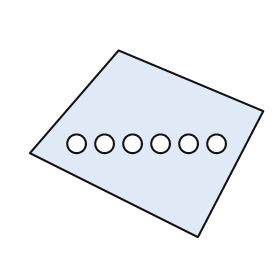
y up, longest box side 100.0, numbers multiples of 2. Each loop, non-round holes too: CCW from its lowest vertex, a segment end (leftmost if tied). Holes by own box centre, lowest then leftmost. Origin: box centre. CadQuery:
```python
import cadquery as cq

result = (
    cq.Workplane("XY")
    .moveTo(22.0, -40.0)
    .lineTo(50.0, 14.0)
    .lineTo(-12.0, 40.0)
    .lineTo(-50.0, -4.0)
    .close()
    .moveTo(-30.0, 0.0)
    .circle(4.0)
    .moveTo(-18.0, 0.0)
    .circle(4.0)
    .moveTo(-6.0, 0.0)
    .circle(4.0)
    .moveTo(6.0, 0.0)
    .circle(4.0)
    .moveTo(18.0, 0.0)
    .circle(4.0)
    .moveTo(30.0, 0.0)
    .circle(4.0)
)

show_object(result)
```